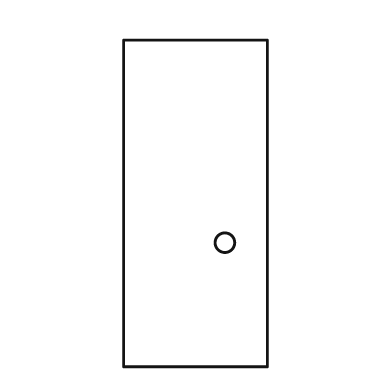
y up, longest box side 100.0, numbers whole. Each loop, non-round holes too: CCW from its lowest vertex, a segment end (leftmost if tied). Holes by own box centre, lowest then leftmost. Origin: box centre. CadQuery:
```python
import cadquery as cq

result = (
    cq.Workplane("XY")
    .moveTo(-22.0, -50.0)
    .lineTo(22.0, -50.0)
    .lineTo(22.0, 50.0)
    .lineTo(-22.0, 50.0)
    .close()
    .moveTo(9.0, -12.0)
    .circle(3.0)
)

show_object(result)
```